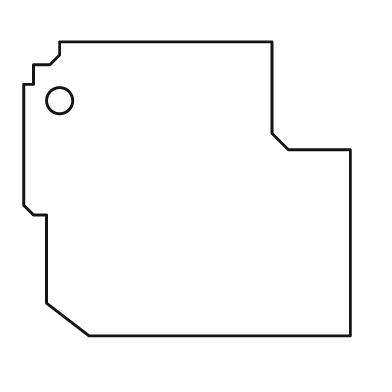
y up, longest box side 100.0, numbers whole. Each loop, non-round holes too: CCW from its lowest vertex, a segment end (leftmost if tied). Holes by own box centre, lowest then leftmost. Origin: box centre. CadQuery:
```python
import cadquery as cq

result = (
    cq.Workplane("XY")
    .moveTo(-30.0, -45.0)
    .lineTo(50.0, -45.0)
    .lineTo(50.0, 12.0)
    .lineTo(31.0, 12.0)
    .lineTo(26.0, 17.0)
    .lineTo(26.0, 45.0)
    .lineTo(-39.0, 45.0)
    .lineTo(-39.0, 41.0)
    .lineTo(-42.0, 38.0)
    .lineTo(-47.0, 38.0)
    .lineTo(-47.0, 32.0)
    .lineTo(-50.0, 32.0)
    .lineTo(-50.0, -5.0)
    .lineTo(-47.0, -8.0)
    .lineTo(-43.0, -8.0)
    .lineTo(-43.0, -35.0)
    .close()
    .moveTo(-39.0, 27.0)
    .circle(4.0)
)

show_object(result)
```